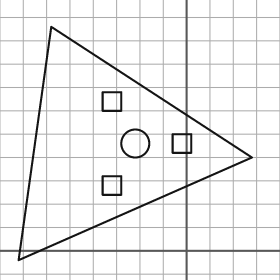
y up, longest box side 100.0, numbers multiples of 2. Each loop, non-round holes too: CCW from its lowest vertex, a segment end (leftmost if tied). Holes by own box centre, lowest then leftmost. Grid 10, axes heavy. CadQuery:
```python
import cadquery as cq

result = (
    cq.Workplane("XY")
    .moveTo(-72.0, -4.0)
    .lineTo(28.0, 40.0)
    .lineTo(-58.0, 96.0)
    .close()
    .moveTo(-36.0, 24.0)
    .lineTo(-28.0, 24.0)
    .lineTo(-28.0, 32.0)
    .lineTo(-36.0, 32.0)
    .close()
    .moveTo(-22.0, 46.0)
    .circle(6.0)
    .moveTo(-6.0, 42.0)
    .lineTo(2.0, 42.0)
    .lineTo(2.0, 50.0)
    .lineTo(-6.0, 50.0)
    .close()
    .moveTo(-36.0, 60.0)
    .lineTo(-28.0, 60.0)
    .lineTo(-28.0, 68.0)
    .lineTo(-36.0, 68.0)
    .close()
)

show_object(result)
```